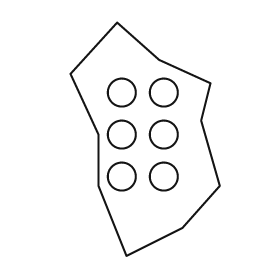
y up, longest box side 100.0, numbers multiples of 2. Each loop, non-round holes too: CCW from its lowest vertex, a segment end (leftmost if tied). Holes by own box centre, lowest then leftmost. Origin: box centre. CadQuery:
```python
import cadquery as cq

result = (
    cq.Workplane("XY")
    .moveTo(-8.0, -50.0)
    .lineTo(16.0, -38.0)
    .lineTo(32.0, -20.0)
    .lineTo(24.0, 8.0)
    .lineTo(28.0, 24.0)
    .lineTo(6.0, 34.0)
    .lineTo(-12.0, 50.0)
    .lineTo(-32.0, 28.0)
    .lineTo(-20.0, 2.0)
    .lineTo(-20.0, -20.0)
    .close()
    .moveTo(-10.0, -16.0)
    .circle(6.0)
    .moveTo(8.0, -16.0)
    .circle(6.0)
    .moveTo(-10.0, 2.0)
    .circle(6.0)
    .moveTo(8.0, 2.0)
    .circle(6.0)
    .moveTo(-10.0, 20.0)
    .circle(6.0)
    .moveTo(8.0, 20.0)
    .circle(6.0)
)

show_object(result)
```